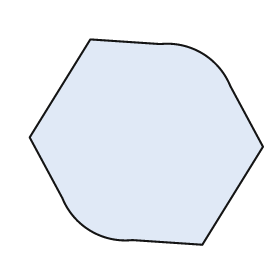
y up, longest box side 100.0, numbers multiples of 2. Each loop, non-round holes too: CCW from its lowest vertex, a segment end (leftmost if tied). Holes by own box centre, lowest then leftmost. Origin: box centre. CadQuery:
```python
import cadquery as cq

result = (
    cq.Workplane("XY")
    .moveTo(24.0, -44.0)
    .lineTo(50.0, -2.0)
    .lineTo(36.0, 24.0)
    .threePointArc((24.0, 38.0), (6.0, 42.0))
    .lineTo(-24.0, 44.0)
    .lineTo(-50.0, 2.0)
    .lineTo(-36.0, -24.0)
    .threePointArc((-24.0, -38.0), (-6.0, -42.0))
    .close()
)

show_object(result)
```